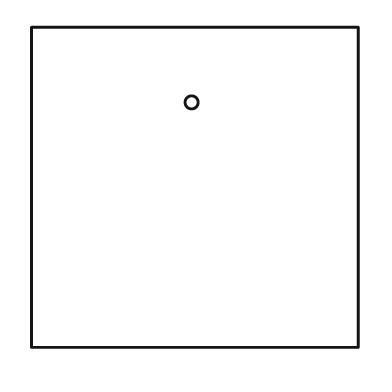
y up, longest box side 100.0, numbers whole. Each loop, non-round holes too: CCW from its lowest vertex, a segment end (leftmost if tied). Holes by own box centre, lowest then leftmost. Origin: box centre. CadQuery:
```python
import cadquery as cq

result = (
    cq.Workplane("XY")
    .moveTo(-50.0, -49.0)
    .lineTo(50.0, -49.0)
    .lineTo(50.0, 49.0)
    .lineTo(-50.0, 49.0)
    .close()
    .moveTo(-1.0, 26.0)
    .circle(2.0)
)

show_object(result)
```